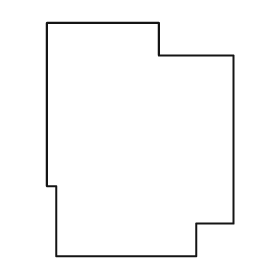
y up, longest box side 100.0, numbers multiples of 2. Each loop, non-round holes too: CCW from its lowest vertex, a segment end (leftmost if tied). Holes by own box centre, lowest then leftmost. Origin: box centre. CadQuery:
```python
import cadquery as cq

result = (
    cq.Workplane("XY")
    .moveTo(-36.0, -50.0)
    .lineTo(24.0, -50.0)
    .lineTo(24.0, -36.0)
    .lineTo(40.0, -36.0)
    .lineTo(40.0, 36.0)
    .lineTo(8.0, 36.0)
    .lineTo(8.0, 50.0)
    .lineTo(-40.0, 50.0)
    .lineTo(-40.0, -20.0)
    .lineTo(-36.0, -20.0)
    .close()
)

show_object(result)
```